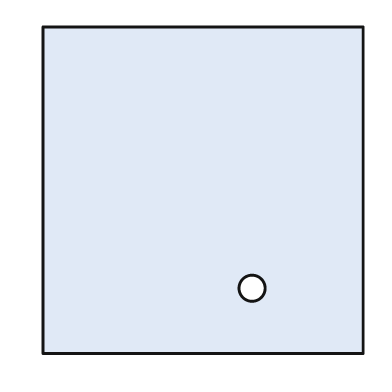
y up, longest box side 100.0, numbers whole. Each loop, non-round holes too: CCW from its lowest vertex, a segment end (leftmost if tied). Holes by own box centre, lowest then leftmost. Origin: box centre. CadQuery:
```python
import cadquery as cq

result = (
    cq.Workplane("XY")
    .moveTo(-49.0, -50.0)
    .lineTo(49.0, -50.0)
    .lineTo(49.0, 50.0)
    .lineTo(-49.0, 50.0)
    .close()
    .moveTo(15.0, -30.0)
    .circle(4.0)
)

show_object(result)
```